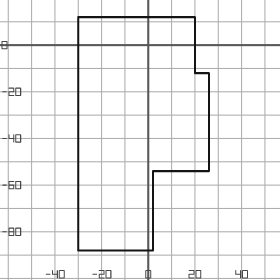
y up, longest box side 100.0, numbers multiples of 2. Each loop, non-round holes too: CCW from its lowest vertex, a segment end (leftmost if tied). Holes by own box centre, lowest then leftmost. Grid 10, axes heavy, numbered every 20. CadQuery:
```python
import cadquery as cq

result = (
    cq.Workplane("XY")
    .moveTo(-30.0, -88.0)
    .lineTo(2.0, -88.0)
    .lineTo(2.0, -54.0)
    .lineTo(26.0, -54.0)
    .lineTo(26.0, -12.0)
    .lineTo(20.0, -12.0)
    .lineTo(20.0, 12.0)
    .lineTo(-30.0, 12.0)
    .close()
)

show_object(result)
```